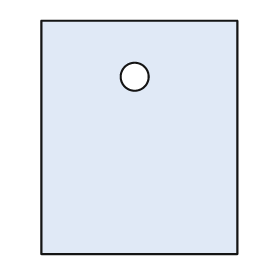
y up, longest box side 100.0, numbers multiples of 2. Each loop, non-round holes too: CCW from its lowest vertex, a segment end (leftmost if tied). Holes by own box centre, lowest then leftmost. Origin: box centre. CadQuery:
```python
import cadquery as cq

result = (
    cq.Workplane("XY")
    .moveTo(-42.0, -50.0)
    .lineTo(42.0, -50.0)
    .lineTo(42.0, 50.0)
    .lineTo(-42.0, 50.0)
    .close()
    .moveTo(-2.0, 26.0)
    .circle(6.0)
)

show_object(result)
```